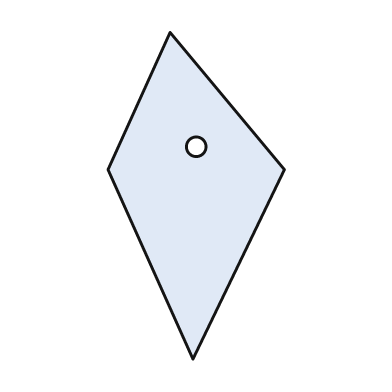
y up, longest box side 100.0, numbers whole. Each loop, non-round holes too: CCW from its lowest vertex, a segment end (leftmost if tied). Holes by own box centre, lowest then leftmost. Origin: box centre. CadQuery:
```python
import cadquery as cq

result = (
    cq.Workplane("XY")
    .moveTo(-1.0, -50.0)
    .lineTo(27.0, 8.0)
    .lineTo(-8.0, 50.0)
    .lineTo(-27.0, 8.0)
    .close()
    .moveTo(0.0, 15.0)
    .circle(3.0)
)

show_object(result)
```